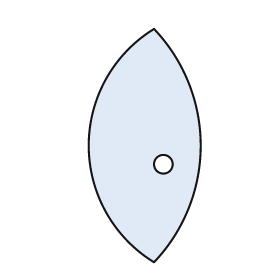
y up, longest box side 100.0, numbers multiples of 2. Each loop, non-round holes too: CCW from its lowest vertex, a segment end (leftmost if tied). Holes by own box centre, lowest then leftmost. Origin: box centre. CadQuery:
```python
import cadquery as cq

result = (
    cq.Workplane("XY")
    .moveTo(4.0, -50.0)
    .threePointArc((24.0, 0.0), (4.0, 50.0))
    .threePointArc((-24.0, 0.0), (4.0, -50.0))
    .close()
    .moveTo(8.0, -8.0)
    .circle(4.0)
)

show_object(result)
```